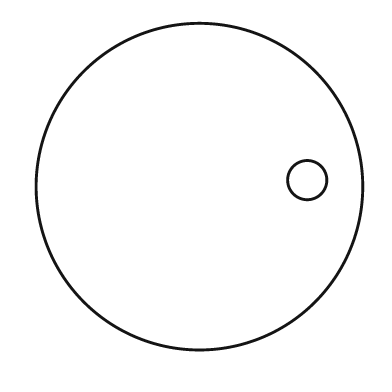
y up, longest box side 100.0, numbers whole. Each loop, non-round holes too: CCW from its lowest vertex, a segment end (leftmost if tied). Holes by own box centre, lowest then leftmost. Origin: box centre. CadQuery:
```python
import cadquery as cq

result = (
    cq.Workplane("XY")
    .moveTo(0.0, 0.0)
    .circle(50.0)
    .moveTo(33.0, 2.0)
    .circle(6.0)
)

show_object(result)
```